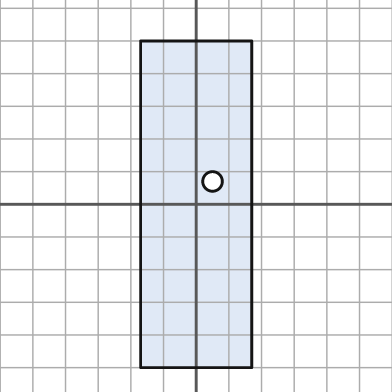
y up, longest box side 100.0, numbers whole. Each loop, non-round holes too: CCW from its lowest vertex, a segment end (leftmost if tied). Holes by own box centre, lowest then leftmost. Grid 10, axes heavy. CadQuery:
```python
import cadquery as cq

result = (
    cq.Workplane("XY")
    .moveTo(-17.0, -50.0)
    .lineTo(17.0, -50.0)
    .lineTo(17.0, 50.0)
    .lineTo(-17.0, 50.0)
    .close()
    .moveTo(5.0, 7.0)
    .circle(3.0)
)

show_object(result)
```